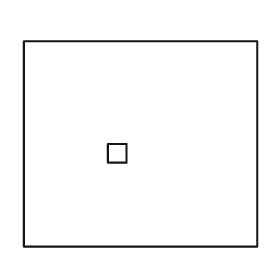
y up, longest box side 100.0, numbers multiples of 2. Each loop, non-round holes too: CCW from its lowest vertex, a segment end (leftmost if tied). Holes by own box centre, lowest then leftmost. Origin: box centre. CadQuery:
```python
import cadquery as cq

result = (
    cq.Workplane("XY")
    .moveTo(-50.0, -44.0)
    .lineTo(50.0, -44.0)
    .lineTo(50.0, 44.0)
    .lineTo(-50.0, 44.0)
    .close()
    .moveTo(-14.0, -8.0)
    .lineTo(-6.0, -8.0)
    .lineTo(-6.0, 0.0)
    .lineTo(-14.0, 0.0)
    .close()
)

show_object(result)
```